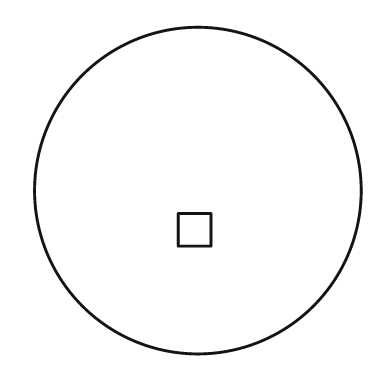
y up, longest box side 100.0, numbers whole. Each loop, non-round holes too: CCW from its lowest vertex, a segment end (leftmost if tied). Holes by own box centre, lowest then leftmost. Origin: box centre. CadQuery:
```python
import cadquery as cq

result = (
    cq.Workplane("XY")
    .moveTo(0.0, 0.0)
    .circle(50.0)
    .moveTo(-6.0, -17.0)
    .lineTo(4.0, -17.0)
    .lineTo(4.0, -7.0)
    .lineTo(-6.0, -7.0)
    .close()
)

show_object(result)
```